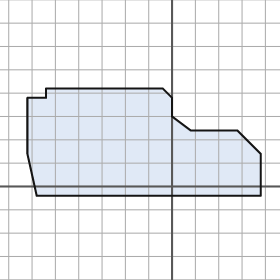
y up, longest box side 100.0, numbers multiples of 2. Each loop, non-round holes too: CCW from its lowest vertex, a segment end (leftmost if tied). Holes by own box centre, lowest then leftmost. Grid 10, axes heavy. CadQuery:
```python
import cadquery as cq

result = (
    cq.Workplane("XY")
    .moveTo(-58.0, -4.0)
    .lineTo(38.0, -4.0)
    .lineTo(38.0, 14.0)
    .lineTo(28.0, 24.0)
    .lineTo(8.0, 24.0)
    .lineTo(0.0, 30.0)
    .lineTo(0.0, 38.0)
    .lineTo(-4.0, 42.0)
    .lineTo(-54.0, 42.0)
    .lineTo(-54.0, 38.0)
    .lineTo(-62.0, 38.0)
    .lineTo(-62.0, 14.0)
    .close()
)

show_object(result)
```